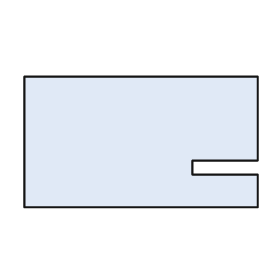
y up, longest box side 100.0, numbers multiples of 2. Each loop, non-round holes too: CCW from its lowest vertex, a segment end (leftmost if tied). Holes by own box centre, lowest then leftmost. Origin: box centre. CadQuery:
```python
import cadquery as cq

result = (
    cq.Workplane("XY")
    .moveTo(-50.0, -28.0)
    .lineTo(50.0, -28.0)
    .lineTo(50.0, -14.0)
    .lineTo(22.0, -14.0)
    .lineTo(22.0, -8.0)
    .lineTo(50.0, -8.0)
    .lineTo(50.0, 28.0)
    .lineTo(-50.0, 28.0)
    .close()
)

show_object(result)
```